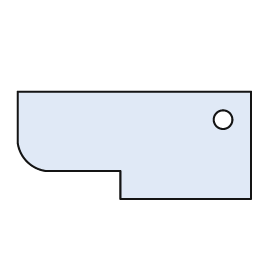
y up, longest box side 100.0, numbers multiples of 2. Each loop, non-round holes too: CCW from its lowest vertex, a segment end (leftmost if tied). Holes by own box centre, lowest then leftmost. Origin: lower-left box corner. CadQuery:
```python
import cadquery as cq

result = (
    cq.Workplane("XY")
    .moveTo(44.0, 0.0)
    .lineTo(100.0, 0.0)
    .lineTo(100.0, 46.0)
    .lineTo(0.0, 46.0)
    .lineTo(0.0, 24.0)
    .threePointArc((4.0, 16.0), (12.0, 12.0))
    .lineTo(44.0, 12.0)
    .close()
    .moveTo(88.0, 34.0)
    .circle(4.0)
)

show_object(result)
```